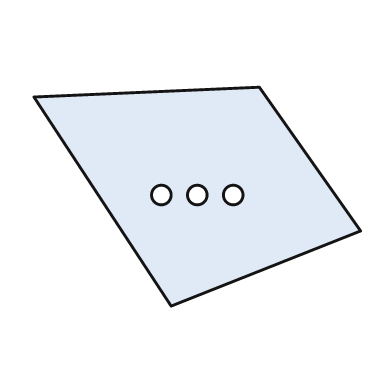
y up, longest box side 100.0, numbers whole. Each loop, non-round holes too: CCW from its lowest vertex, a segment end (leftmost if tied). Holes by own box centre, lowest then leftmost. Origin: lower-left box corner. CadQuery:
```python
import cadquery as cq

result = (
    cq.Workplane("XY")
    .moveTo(42.0, 0.0)
    .lineTo(100.0, 23.0)
    .lineTo(69.0, 67.0)
    .lineTo(0.0, 64.0)
    .close()
    .moveTo(39.0, 34.0)
    .circle(3.0)
    .moveTo(50.0, 34.0)
    .circle(3.0)
    .moveTo(61.0, 34.0)
    .circle(3.0)
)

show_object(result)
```